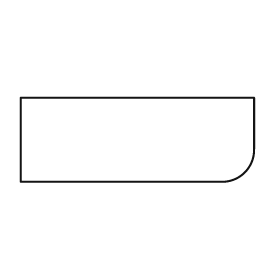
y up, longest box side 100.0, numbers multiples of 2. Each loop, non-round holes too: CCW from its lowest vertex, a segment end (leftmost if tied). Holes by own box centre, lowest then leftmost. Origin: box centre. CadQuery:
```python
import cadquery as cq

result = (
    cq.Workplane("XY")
    .moveTo(-50.0, -18.0)
    .lineTo(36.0, -18.0)
    .threePointArc((46.0, -14.0), (50.0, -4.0))
    .lineTo(50.0, 18.0)
    .lineTo(-50.0, 18.0)
    .close()
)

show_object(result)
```